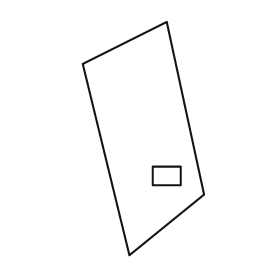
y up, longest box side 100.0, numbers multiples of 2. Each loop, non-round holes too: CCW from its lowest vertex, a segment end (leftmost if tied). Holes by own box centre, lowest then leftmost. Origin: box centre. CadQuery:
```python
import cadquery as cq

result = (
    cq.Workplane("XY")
    .moveTo(-6.0, -50.0)
    .lineTo(26.0, -24.0)
    .lineTo(10.0, 50.0)
    .lineTo(-26.0, 32.0)
    .close()
    .moveTo(4.0, -20.0)
    .lineTo(16.0, -20.0)
    .lineTo(16.0, -12.0)
    .lineTo(4.0, -12.0)
    .close()
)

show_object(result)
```